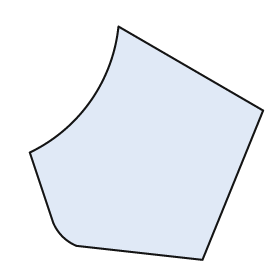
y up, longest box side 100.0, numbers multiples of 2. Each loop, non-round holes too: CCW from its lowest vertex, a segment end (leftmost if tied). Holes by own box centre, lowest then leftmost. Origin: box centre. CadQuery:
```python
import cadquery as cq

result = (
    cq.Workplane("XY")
    .moveTo(24.0, -50.0)
    .lineTo(50.0, 14.0)
    .lineTo(-12.0, 50.0)
    .threePointArc((-24.0, 18.0), (-50.0, -4.0))
    .lineTo(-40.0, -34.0)
    .threePointArc((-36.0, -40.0), (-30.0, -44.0))
    .close()
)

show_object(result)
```